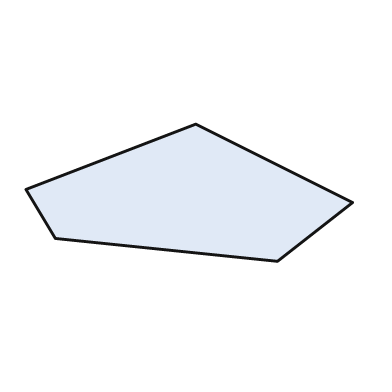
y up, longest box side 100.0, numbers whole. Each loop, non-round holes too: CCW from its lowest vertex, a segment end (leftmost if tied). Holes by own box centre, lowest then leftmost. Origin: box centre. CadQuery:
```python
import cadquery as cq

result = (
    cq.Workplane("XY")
    .moveTo(27.0, -21.0)
    .lineTo(50.0, -3.0)
    .lineTo(2.0, 21.0)
    .lineTo(-50.0, 1.0)
    .lineTo(-41.0, -14.0)
    .close()
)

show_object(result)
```